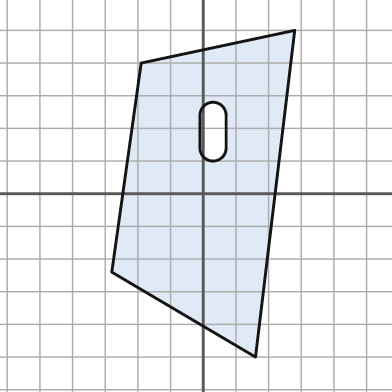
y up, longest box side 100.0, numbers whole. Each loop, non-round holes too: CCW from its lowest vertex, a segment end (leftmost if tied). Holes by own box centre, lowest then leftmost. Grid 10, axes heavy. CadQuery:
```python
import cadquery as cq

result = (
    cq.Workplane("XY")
    .moveTo(16.0, -50.0)
    .lineTo(28.0, 50.0)
    .lineTo(-19.0, 40.0)
    .lineTo(-28.0, -24.0)
    .close()
    .moveTo(-1.0, 14.0)
    .threePointArc((3.0, 10.0), (7.0, 14.0))
    .lineTo(7.0, 24.0)
    .threePointArc((3.0, 28.0), (-1.0, 24.0))
    .close()
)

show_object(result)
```